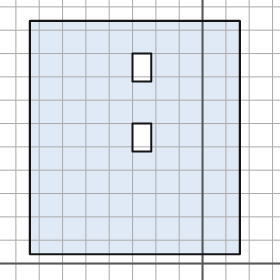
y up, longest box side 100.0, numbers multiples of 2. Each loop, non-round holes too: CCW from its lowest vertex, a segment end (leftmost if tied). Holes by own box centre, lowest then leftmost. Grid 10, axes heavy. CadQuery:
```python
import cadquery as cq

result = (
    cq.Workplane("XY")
    .moveTo(-74.0, 4.0)
    .lineTo(16.0, 4.0)
    .lineTo(16.0, 104.0)
    .lineTo(-74.0, 104.0)
    .close()
    .moveTo(-30.0, 48.0)
    .lineTo(-22.0, 48.0)
    .lineTo(-22.0, 60.0)
    .lineTo(-30.0, 60.0)
    .close()
    .moveTo(-30.0, 78.0)
    .lineTo(-22.0, 78.0)
    .lineTo(-22.0, 90.0)
    .lineTo(-30.0, 90.0)
    .close()
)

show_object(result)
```